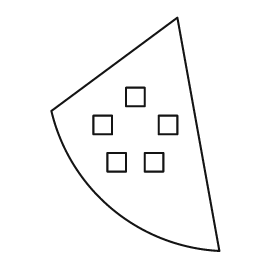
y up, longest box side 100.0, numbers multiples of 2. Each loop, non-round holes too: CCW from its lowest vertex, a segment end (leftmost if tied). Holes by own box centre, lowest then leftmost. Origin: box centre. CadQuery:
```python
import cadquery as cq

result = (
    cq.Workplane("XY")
    .moveTo(36.0, -50.0)
    .lineTo(18.0, 50.0)
    .lineTo(-36.0, 10.0)
    .threePointArc((-10.0, -32.0), (36.0, -50.0))
    .close()
    .moveTo(-12.0, -16.0)
    .lineTo(-4.0, -16.0)
    .lineTo(-4.0, -8.0)
    .lineTo(-12.0, -8.0)
    .close()
    .moveTo(4.0, -16.0)
    .lineTo(12.0, -16.0)
    .lineTo(12.0, -8.0)
    .lineTo(4.0, -8.0)
    .close()
    .moveTo(-18.0, 0.0)
    .lineTo(-10.0, 0.0)
    .lineTo(-10.0, 8.0)
    .lineTo(-18.0, 8.0)
    .close()
    .moveTo(10.0, 0.0)
    .lineTo(18.0, 0.0)
    .lineTo(18.0, 8.0)
    .lineTo(10.0, 8.0)
    .close()
    .moveTo(-4.0, 12.0)
    .lineTo(4.0, 12.0)
    .lineTo(4.0, 20.0)
    .lineTo(-4.0, 20.0)
    .close()
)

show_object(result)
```